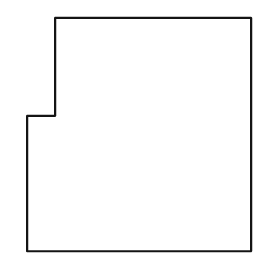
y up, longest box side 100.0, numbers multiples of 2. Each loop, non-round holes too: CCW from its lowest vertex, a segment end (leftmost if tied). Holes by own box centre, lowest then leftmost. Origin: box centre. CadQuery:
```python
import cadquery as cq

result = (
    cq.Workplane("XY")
    .moveTo(-48.0, -50.0)
    .lineTo(48.0, -50.0)
    .lineTo(48.0, 50.0)
    .lineTo(-36.0, 50.0)
    .lineTo(-36.0, 8.0)
    .lineTo(-48.0, 8.0)
    .close()
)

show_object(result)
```